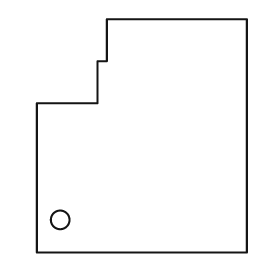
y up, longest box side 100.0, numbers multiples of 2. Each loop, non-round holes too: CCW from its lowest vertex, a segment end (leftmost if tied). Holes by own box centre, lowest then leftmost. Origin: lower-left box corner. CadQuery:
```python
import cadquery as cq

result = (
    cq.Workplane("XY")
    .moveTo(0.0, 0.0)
    .lineTo(90.0, 0.0)
    .lineTo(90.0, 100.0)
    .lineTo(30.0, 100.0)
    .lineTo(30.0, 82.0)
    .lineTo(26.0, 82.0)
    .lineTo(26.0, 64.0)
    .lineTo(0.0, 64.0)
    .close()
    .moveTo(10.0, 14.0)
    .circle(4.0)
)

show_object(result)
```